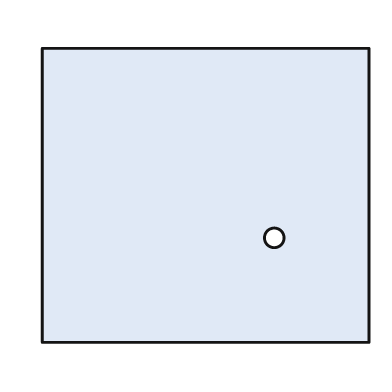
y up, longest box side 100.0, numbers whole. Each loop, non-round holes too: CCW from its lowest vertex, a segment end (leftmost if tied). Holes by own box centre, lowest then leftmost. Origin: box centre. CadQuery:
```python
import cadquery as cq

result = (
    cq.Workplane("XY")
    .moveTo(-50.0, -45.0)
    .lineTo(50.0, -45.0)
    .lineTo(50.0, 45.0)
    .lineTo(-50.0, 45.0)
    .close()
    .moveTo(21.0, -13.0)
    .circle(3.0)
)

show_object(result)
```